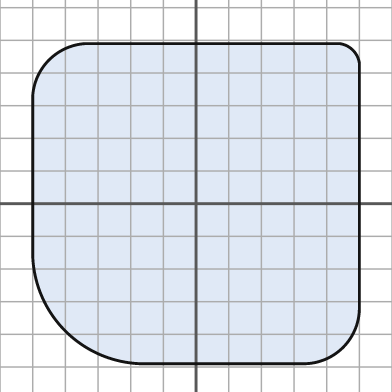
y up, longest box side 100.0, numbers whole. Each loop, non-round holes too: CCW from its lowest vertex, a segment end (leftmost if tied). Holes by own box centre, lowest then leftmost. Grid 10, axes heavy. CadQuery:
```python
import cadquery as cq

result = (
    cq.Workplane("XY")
    .moveTo(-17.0, -49.0)
    .lineTo(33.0, -49.0)
    .threePointArc((45.0, -44.0), (50.0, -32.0))
    .lineTo(50.0, 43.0)
    .threePointArc((48.0, 47.0), (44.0, 49.0))
    .lineTo(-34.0, 49.0)
    .threePointArc((-45.0, 44.0), (-50.0, 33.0))
    .lineTo(-50.0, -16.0)
    .threePointArc((-40.0, -39.0), (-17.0, -49.0))
    .close()
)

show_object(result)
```